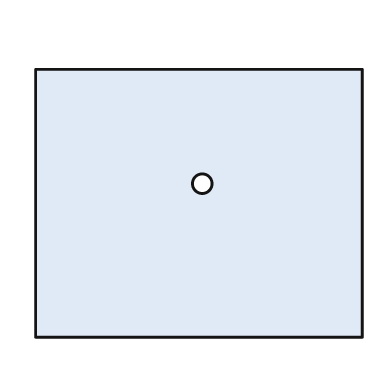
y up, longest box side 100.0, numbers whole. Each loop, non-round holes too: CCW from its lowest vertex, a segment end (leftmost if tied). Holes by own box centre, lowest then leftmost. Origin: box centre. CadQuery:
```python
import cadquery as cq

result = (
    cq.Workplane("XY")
    .moveTo(-50.0, -41.0)
    .lineTo(50.0, -41.0)
    .lineTo(50.0, 41.0)
    .lineTo(-50.0, 41.0)
    .close()
    .moveTo(1.0, 6.0)
    .circle(3.0)
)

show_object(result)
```